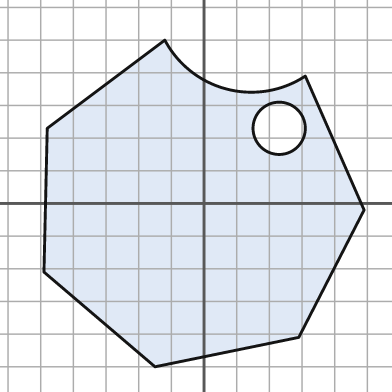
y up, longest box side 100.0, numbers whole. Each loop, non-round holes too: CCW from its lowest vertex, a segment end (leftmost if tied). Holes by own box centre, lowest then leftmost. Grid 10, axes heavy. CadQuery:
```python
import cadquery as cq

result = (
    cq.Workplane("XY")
    .moveTo(-15.0, -50.0)
    .lineTo(29.0, -41.0)
    .lineTo(49.0, -2.0)
    .lineTo(31.0, 39.0)
    .threePointArc((7.0, 35.0), (-12.0, 50.0))
    .lineTo(-48.0, 23.0)
    .lineTo(-49.0, -21.0)
    .close()
    .moveTo(23.0, 23.0)
    .circle(8.0)
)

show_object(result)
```